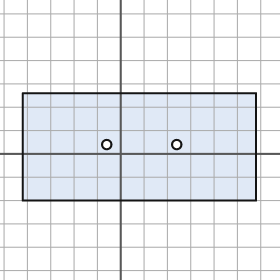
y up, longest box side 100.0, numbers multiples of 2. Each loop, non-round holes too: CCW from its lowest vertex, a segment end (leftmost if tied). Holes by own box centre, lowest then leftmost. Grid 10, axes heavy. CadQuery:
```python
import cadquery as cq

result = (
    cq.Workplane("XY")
    .moveTo(-42.0, -20.0)
    .lineTo(58.0, -20.0)
    .lineTo(58.0, 26.0)
    .lineTo(-42.0, 26.0)
    .close()
    .moveTo(-6.0, 4.0)
    .circle(2.0)
    .moveTo(24.0, 4.0)
    .circle(2.0)
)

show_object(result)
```